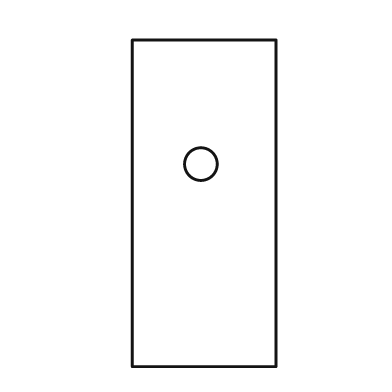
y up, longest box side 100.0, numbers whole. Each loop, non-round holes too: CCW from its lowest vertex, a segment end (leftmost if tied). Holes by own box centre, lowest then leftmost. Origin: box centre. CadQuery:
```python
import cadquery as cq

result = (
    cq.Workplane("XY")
    .moveTo(-22.0, -50.0)
    .lineTo(22.0, -50.0)
    .lineTo(22.0, 50.0)
    .lineTo(-22.0, 50.0)
    .close()
    .moveTo(-1.0, 12.0)
    .circle(5.0)
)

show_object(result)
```